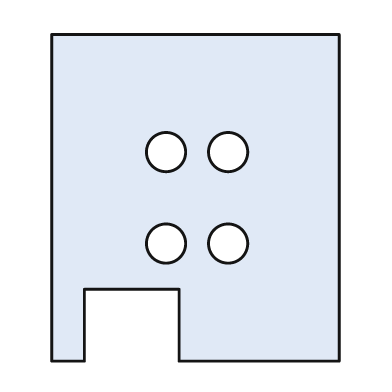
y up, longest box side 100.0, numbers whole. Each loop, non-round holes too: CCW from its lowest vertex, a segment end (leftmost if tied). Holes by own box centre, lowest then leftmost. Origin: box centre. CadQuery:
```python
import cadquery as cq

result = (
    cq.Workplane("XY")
    .moveTo(-44.0, -50.0)
    .lineTo(-34.0, -50.0)
    .lineTo(-34.0, -28.0)
    .lineTo(-5.0, -28.0)
    .lineTo(-5.0, -50.0)
    .lineTo(44.0, -50.0)
    .lineTo(44.0, 50.0)
    .lineTo(-44.0, 50.0)
    .close()
    .moveTo(-9.0, -14.0)
    .circle(6.0)
    .moveTo(10.0, -14.0)
    .circle(6.0)
    .moveTo(-9.0, 14.0)
    .circle(6.0)
    .moveTo(10.0, 14.0)
    .circle(6.0)
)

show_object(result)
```